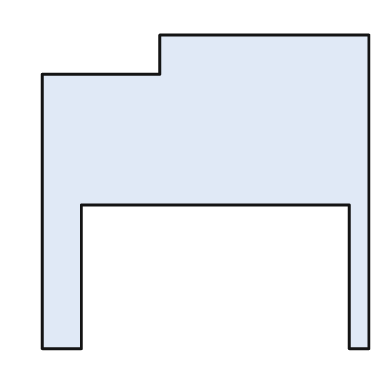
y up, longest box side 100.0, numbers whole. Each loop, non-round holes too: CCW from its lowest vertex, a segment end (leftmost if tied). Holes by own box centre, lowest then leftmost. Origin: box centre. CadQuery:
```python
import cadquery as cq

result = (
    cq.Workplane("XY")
    .moveTo(-50.0, -48.0)
    .lineTo(-38.0, -48.0)
    .lineTo(-38.0, -4.0)
    .lineTo(44.0, -4.0)
    .lineTo(44.0, -48.0)
    .lineTo(50.0, -48.0)
    .lineTo(50.0, 48.0)
    .lineTo(-14.0, 48.0)
    .lineTo(-14.0, 36.0)
    .lineTo(-50.0, 36.0)
    .close()
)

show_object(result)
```